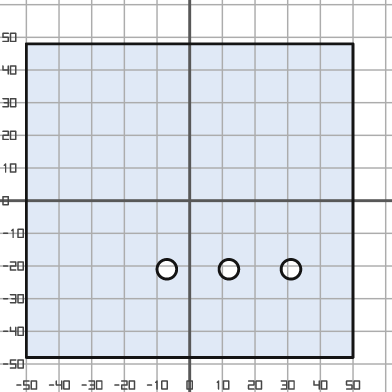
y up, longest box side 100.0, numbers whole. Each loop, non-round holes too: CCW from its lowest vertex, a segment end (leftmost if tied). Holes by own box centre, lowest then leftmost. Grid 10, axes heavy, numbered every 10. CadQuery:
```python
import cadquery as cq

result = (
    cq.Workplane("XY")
    .moveTo(-50.0, -48.0)
    .lineTo(50.0, -48.0)
    .lineTo(50.0, 48.0)
    .lineTo(-50.0, 48.0)
    .close()
    .moveTo(-7.0, -21.0)
    .circle(3.0)
    .moveTo(12.0, -21.0)
    .circle(3.0)
    .moveTo(31.0, -21.0)
    .circle(3.0)
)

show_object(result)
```